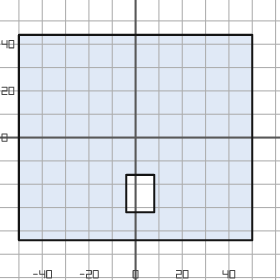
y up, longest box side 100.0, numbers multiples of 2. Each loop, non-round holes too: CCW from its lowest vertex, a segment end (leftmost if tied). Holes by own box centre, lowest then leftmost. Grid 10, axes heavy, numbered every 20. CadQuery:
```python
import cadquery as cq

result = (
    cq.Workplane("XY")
    .moveTo(-50.0, -44.0)
    .lineTo(50.0, -44.0)
    .lineTo(50.0, 44.0)
    .lineTo(-50.0, 44.0)
    .close()
    .moveTo(-4.0, -32.0)
    .lineTo(8.0, -32.0)
    .lineTo(8.0, -16.0)
    .lineTo(-4.0, -16.0)
    .close()
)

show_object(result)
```